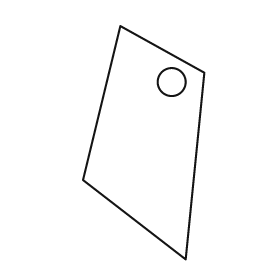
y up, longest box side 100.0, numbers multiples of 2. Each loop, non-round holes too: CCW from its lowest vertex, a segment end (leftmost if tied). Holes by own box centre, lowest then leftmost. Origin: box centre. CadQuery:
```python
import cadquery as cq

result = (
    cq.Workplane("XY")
    .moveTo(18.0, -50.0)
    .lineTo(26.0, 30.0)
    .lineTo(-10.0, 50.0)
    .lineTo(-26.0, -16.0)
    .close()
    .moveTo(12.0, 26.0)
    .circle(6.0)
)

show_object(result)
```